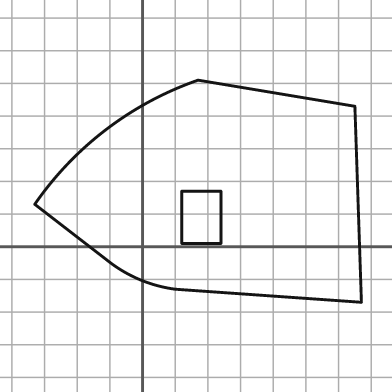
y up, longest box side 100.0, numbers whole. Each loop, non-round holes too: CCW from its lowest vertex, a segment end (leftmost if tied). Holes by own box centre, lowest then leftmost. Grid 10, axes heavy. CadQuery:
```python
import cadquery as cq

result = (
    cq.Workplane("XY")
    .moveTo(67.0, -17.0)
    .lineTo(65.0, 43.0)
    .lineTo(17.0, 51.0)
    .threePointArc((-11.0, 36.0), (-33.0, 13.0))
    .lineTo(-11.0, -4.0)
    .threePointArc((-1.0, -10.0), (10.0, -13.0))
    .close()
    .moveTo(12.0, 1.0)
    .lineTo(24.0, 1.0)
    .lineTo(24.0, 17.0)
    .lineTo(12.0, 17.0)
    .close()
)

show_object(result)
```